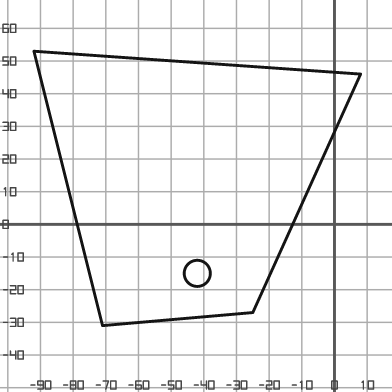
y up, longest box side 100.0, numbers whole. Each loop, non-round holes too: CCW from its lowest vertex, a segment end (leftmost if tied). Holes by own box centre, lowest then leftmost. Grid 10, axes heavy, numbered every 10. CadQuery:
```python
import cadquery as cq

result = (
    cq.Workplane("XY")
    .moveTo(-71.0, -31.0)
    .lineTo(-25.0, -27.0)
    .lineTo(8.0, 46.0)
    .lineTo(-92.0, 53.0)
    .close()
    .moveTo(-42.0, -15.0)
    .circle(4.0)
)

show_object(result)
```